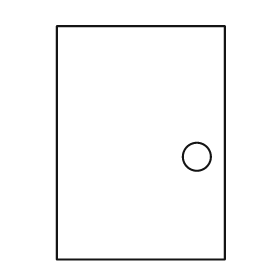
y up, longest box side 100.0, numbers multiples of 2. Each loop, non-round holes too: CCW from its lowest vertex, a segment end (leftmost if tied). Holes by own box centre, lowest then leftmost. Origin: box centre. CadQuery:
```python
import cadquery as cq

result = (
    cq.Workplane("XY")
    .moveTo(-36.0, -50.0)
    .lineTo(36.0, -50.0)
    .lineTo(36.0, 50.0)
    .lineTo(-36.0, 50.0)
    .close()
    .moveTo(24.0, -6.0)
    .circle(6.0)
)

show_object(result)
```